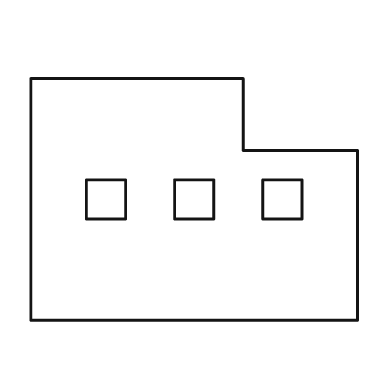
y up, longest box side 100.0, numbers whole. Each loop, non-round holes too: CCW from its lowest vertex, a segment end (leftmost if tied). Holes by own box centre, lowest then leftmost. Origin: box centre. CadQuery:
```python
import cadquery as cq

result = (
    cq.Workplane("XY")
    .moveTo(-50.0, -37.0)
    .lineTo(50.0, -37.0)
    .lineTo(50.0, 15.0)
    .lineTo(15.0, 15.0)
    .lineTo(15.0, 37.0)
    .lineTo(-50.0, 37.0)
    .close()
    .moveTo(-33.0, -6.0)
    .lineTo(-21.0, -6.0)
    .lineTo(-21.0, 6.0)
    .lineTo(-33.0, 6.0)
    .close()
    .moveTo(-6.0, -6.0)
    .lineTo(6.0, -6.0)
    .lineTo(6.0, 6.0)
    .lineTo(-6.0, 6.0)
    .close()
    .moveTo(21.0, -6.0)
    .lineTo(33.0, -6.0)
    .lineTo(33.0, 6.0)
    .lineTo(21.0, 6.0)
    .close()
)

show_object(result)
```